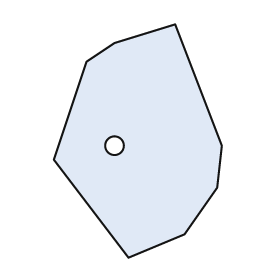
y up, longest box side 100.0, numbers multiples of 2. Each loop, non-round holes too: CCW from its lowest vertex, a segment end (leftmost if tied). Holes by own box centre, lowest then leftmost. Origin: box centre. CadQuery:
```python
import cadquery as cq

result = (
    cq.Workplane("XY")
    .moveTo(-4.0, -50.0)
    .lineTo(20.0, -40.0)
    .lineTo(34.0, -20.0)
    .lineTo(36.0, -2.0)
    .lineTo(16.0, 50.0)
    .lineTo(-10.0, 42.0)
    .lineTo(-22.0, 34.0)
    .lineTo(-36.0, -8.0)
    .close()
    .moveTo(-10.0, -2.0)
    .circle(4.0)
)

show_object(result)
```